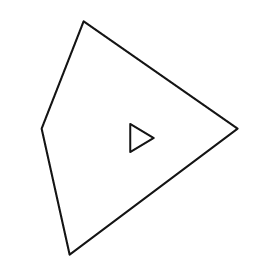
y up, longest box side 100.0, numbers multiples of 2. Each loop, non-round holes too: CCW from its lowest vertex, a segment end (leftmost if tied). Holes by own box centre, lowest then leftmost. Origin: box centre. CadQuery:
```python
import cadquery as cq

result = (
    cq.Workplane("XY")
    .moveTo(-30.0, -50.0)
    .lineTo(42.0, 4.0)
    .lineTo(-24.0, 50.0)
    .lineTo(-42.0, 4.0)
    .close()
    .moveTo(-4.0, -6.0)
    .lineTo(6.0, 0.0)
    .lineTo(-4.0, 6.0)
    .close()
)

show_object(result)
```